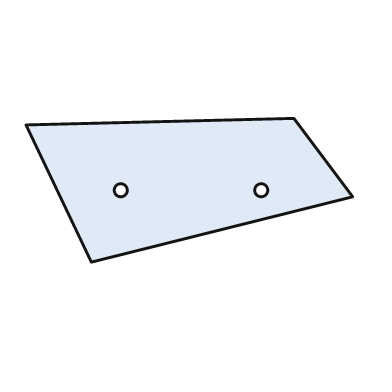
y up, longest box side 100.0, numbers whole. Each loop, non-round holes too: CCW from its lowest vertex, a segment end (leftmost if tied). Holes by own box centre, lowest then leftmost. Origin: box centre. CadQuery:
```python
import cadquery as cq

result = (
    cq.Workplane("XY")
    .moveTo(-30.0, -22.0)
    .lineTo(50.0, -2.0)
    .lineTo(32.0, 22.0)
    .lineTo(-50.0, 20.0)
    .close()
    .moveTo(-21.0, 0.0)
    .circle(2.0)
    .moveTo(22.0, 0.0)
    .circle(2.0)
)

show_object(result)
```